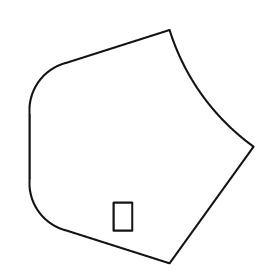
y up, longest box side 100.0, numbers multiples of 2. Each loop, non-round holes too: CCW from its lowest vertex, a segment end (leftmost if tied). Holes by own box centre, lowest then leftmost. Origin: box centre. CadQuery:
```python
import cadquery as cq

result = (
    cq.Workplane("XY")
    .moveTo(12.0, -50.0)
    .lineTo(48.0, 0.0)
    .threePointArc((26.0, 22.0), (12.0, 50.0))
    .lineTo(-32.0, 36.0)
    .threePointArc((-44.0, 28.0), (-48.0, 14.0))
    .lineTo(-48.0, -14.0)
    .threePointArc((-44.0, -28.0), (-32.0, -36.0))
    .close()
    .moveTo(-12.0, -36.0)
    .lineTo(-4.0, -36.0)
    .lineTo(-4.0, -24.0)
    .lineTo(-12.0, -24.0)
    .close()
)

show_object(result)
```